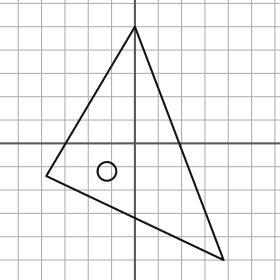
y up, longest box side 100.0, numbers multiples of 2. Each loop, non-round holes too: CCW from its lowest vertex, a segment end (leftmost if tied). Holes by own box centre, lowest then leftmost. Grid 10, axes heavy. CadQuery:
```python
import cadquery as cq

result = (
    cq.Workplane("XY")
    .moveTo(38.0, -50.0)
    .lineTo(0.0, 50.0)
    .lineTo(-38.0, -14.0)
    .close()
    .moveTo(-12.0, -12.0)
    .circle(4.0)
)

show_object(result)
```